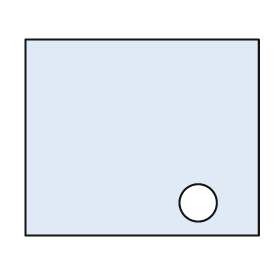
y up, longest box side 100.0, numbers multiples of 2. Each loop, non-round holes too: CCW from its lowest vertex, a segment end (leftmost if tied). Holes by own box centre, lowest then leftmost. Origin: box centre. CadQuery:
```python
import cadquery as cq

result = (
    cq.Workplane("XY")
    .moveTo(-50.0, -42.0)
    .lineTo(50.0, -42.0)
    .lineTo(50.0, 42.0)
    .lineTo(-50.0, 42.0)
    .close()
    .moveTo(24.0, -28.0)
    .circle(8.0)
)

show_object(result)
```